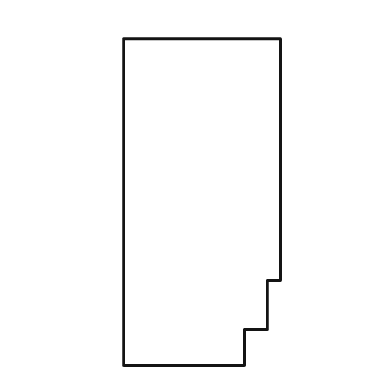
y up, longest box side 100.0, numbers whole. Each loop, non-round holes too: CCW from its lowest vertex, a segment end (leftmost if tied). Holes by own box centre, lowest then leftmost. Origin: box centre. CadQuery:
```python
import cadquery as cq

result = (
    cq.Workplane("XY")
    .moveTo(-24.0, -50.0)
    .lineTo(13.0, -50.0)
    .lineTo(13.0, -39.0)
    .lineTo(20.0, -39.0)
    .lineTo(20.0, -24.0)
    .lineTo(24.0, -24.0)
    .lineTo(24.0, 50.0)
    .lineTo(-24.0, 50.0)
    .close()
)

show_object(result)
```